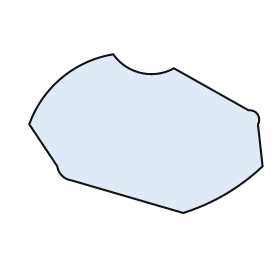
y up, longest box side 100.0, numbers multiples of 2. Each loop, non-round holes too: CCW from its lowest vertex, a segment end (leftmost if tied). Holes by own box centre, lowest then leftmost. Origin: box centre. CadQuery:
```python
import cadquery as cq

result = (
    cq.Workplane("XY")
    .moveTo(16.0, -34.0)
    .threePointArc((34.0, -26.0), (50.0, -14.0))
    .lineTo(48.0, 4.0)
    .threePointArc((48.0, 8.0), (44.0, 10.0))
    .lineTo(12.0, 28.0)
    .threePointArc((-2.0, 26.0), (-14.0, 34.0))
    .threePointArc((-36.0, 24.0), (-50.0, 4.0))
    .lineTo(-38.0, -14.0)
    .threePointArc((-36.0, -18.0), (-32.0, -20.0))
    .close()
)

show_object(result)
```